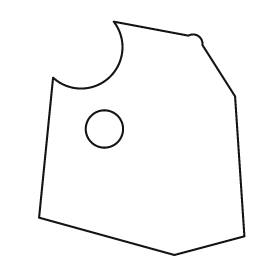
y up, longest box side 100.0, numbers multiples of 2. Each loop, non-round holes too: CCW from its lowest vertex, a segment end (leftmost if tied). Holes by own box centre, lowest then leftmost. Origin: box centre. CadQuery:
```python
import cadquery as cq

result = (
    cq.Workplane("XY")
    .moveTo(14.0, -50.0)
    .lineTo(44.0, -42.0)
    .lineTo(40.0, 18.0)
    .lineTo(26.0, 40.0)
    .threePointArc((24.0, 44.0), (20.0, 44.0))
    .lineTo(-12.0, 50.0)
    .threePointArc((-14.0, 26.0), (-38.0, 26.0))
    .lineTo(-44.0, -34.0)
    .close()
    .moveTo(-16.0, 4.0)
    .circle(8.0)
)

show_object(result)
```